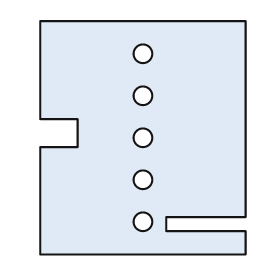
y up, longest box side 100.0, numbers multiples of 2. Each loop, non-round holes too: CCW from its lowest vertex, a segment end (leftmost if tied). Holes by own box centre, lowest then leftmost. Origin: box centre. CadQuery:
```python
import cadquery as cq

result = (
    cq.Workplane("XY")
    .moveTo(-44.0, -50.0)
    .lineTo(44.0, -50.0)
    .lineTo(44.0, -40.0)
    .lineTo(10.0, -40.0)
    .lineTo(10.0, -34.0)
    .lineTo(44.0, -34.0)
    .lineTo(44.0, 50.0)
    .lineTo(-44.0, 50.0)
    .lineTo(-44.0, 8.0)
    .lineTo(-28.0, 8.0)
    .lineTo(-28.0, -4.0)
    .lineTo(-44.0, -4.0)
    .close()
    .moveTo(0.0, -36.0)
    .circle(4.0)
    .moveTo(0.0, -18.0)
    .circle(4.0)
    .moveTo(0.0, 0.0)
    .circle(4.0)
    .moveTo(0.0, 18.0)
    .circle(4.0)
    .moveTo(0.0, 36.0)
    .circle(4.0)
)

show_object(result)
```